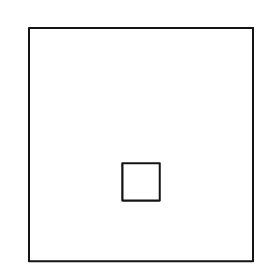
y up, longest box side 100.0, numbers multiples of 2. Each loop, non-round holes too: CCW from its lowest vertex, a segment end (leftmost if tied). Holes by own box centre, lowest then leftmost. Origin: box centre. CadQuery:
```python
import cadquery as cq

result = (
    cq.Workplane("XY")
    .moveTo(-48.0, -50.0)
    .lineTo(48.0, -50.0)
    .lineTo(48.0, 50.0)
    .lineTo(-48.0, 50.0)
    .close()
    .moveTo(-8.0, -24.0)
    .lineTo(8.0, -24.0)
    .lineTo(8.0, -8.0)
    .lineTo(-8.0, -8.0)
    .close()
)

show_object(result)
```